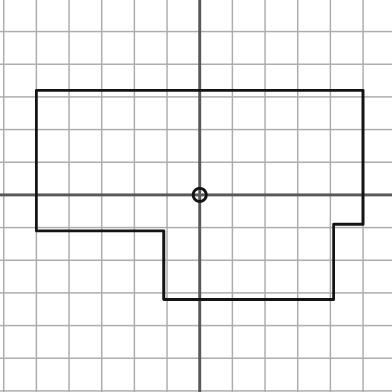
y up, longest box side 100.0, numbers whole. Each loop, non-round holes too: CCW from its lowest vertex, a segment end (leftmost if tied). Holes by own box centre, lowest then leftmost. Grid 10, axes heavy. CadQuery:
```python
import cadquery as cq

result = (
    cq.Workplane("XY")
    .moveTo(-11.0, -32.0)
    .lineTo(41.0, -32.0)
    .lineTo(41.0, -9.0)
    .lineTo(50.0, -9.0)
    .lineTo(50.0, 32.0)
    .lineTo(-50.0, 32.0)
    .lineTo(-50.0, -11.0)
    .lineTo(-11.0, -11.0)
    .close()
    .moveTo(0.0, 0.0)
    .circle(2.0)
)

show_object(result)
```